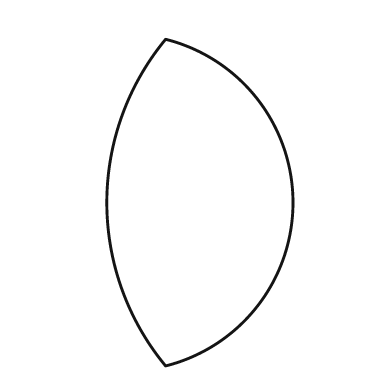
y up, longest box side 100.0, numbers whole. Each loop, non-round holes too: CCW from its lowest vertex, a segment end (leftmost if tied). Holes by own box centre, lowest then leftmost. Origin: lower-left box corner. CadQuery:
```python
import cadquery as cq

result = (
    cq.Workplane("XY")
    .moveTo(18.0, 0.0)
    .threePointArc((57.0, 50.0), (18.0, 100.0))
    .threePointArc((0.0, 50.0), (18.0, 0.0))
    .close()
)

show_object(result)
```